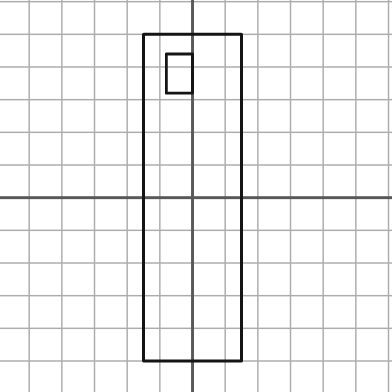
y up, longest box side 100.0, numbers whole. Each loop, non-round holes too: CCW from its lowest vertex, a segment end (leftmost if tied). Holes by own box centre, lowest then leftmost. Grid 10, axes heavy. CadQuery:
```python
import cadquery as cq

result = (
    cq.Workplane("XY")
    .moveTo(-15.0, -50.0)
    .lineTo(15.0, -50.0)
    .lineTo(15.0, 50.0)
    .lineTo(-15.0, 50.0)
    .close()
    .moveTo(-8.0, 32.0)
    .lineTo(0.0, 32.0)
    .lineTo(0.0, 44.0)
    .lineTo(-8.0, 44.0)
    .close()
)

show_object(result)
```